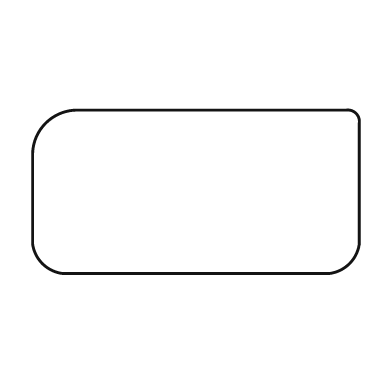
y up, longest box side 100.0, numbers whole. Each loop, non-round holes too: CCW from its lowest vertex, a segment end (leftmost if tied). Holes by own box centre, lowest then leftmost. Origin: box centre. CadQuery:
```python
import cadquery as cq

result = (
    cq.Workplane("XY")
    .moveTo(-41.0, -25.0)
    .lineTo(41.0, -25.0)
    .threePointArc((47.0, -22.0), (50.0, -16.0))
    .lineTo(50.0, 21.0)
    .threePointArc((49.0, 24.0), (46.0, 25.0))
    .lineTo(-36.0, 25.0)
    .threePointArc((-46.0, 21.0), (-50.0, 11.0))
    .lineTo(-50.0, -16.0)
    .threePointArc((-47.0, -22.0), (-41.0, -25.0))
    .close()
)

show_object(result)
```